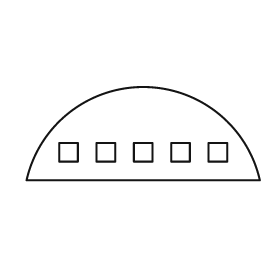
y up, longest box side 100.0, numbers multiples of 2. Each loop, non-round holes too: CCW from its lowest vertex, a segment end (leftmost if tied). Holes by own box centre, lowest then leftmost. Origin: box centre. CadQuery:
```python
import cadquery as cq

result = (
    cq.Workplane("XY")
    .moveTo(-50.0, -20.0)
    .lineTo(50.0, -20.0)
    .threePointArc((0.0, 20.0), (-50.0, -20.0))
    .close()
    .moveTo(-36.0, -12.0)
    .lineTo(-28.0, -12.0)
    .lineTo(-28.0, -4.0)
    .lineTo(-36.0, -4.0)
    .close()
    .moveTo(-20.0, -12.0)
    .lineTo(-12.0, -12.0)
    .lineTo(-12.0, -4.0)
    .lineTo(-20.0, -4.0)
    .close()
    .moveTo(-4.0, -12.0)
    .lineTo(4.0, -12.0)
    .lineTo(4.0, -4.0)
    .lineTo(-4.0, -4.0)
    .close()
    .moveTo(12.0, -12.0)
    .lineTo(20.0, -12.0)
    .lineTo(20.0, -4.0)
    .lineTo(12.0, -4.0)
    .close()
    .moveTo(28.0, -12.0)
    .lineTo(36.0, -12.0)
    .lineTo(36.0, -4.0)
    .lineTo(28.0, -4.0)
    .close()
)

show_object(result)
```